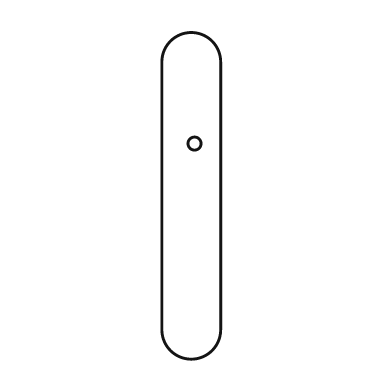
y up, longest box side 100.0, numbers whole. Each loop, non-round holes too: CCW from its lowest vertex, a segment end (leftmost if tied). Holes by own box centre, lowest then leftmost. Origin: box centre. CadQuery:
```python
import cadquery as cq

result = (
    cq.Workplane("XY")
    .moveTo(-9.0, -41.0)
    .threePointArc((0.0, -50.0), (9.0, -41.0))
    .lineTo(9.0, 41.0)
    .threePointArc((0.0, 50.0), (-9.0, 41.0))
    .close()
    .moveTo(1.0, 16.0)
    .circle(2.0)
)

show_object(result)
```